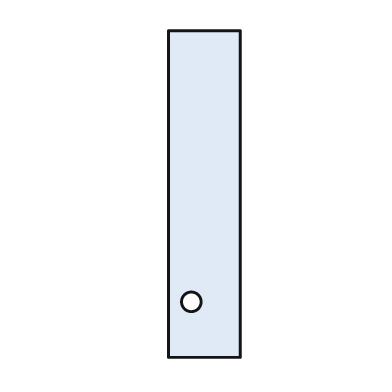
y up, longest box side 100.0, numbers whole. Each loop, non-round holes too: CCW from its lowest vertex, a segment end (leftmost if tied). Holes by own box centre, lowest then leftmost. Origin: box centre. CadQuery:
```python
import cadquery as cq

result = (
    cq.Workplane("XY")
    .moveTo(-11.0, -50.0)
    .lineTo(11.0, -50.0)
    .lineTo(11.0, 50.0)
    .lineTo(-11.0, 50.0)
    .close()
    .moveTo(-4.0, -33.0)
    .circle(3.0)
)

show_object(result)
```